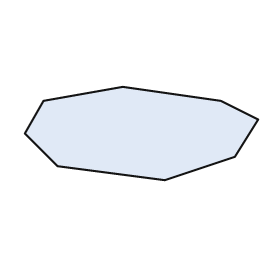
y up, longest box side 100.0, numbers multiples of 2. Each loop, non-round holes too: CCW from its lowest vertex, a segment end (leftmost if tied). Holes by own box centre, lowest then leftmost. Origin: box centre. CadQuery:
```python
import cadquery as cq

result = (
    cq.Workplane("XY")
    .moveTo(10.0, -20.0)
    .lineTo(40.0, -10.0)
    .lineTo(50.0, 6.0)
    .lineTo(34.0, 14.0)
    .lineTo(-8.0, 20.0)
    .lineTo(-42.0, 14.0)
    .lineTo(-50.0, 0.0)
    .lineTo(-36.0, -14.0)
    .close()
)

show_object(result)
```